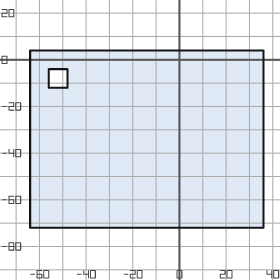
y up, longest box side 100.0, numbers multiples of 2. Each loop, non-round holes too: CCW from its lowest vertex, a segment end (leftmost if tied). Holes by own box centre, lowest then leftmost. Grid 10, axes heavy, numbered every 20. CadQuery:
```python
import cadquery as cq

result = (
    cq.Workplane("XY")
    .moveTo(-64.0, -72.0)
    .lineTo(36.0, -72.0)
    .lineTo(36.0, 4.0)
    .lineTo(-64.0, 4.0)
    .close()
    .moveTo(-56.0, -12.0)
    .lineTo(-48.0, -12.0)
    .lineTo(-48.0, -4.0)
    .lineTo(-56.0, -4.0)
    .close()
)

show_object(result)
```